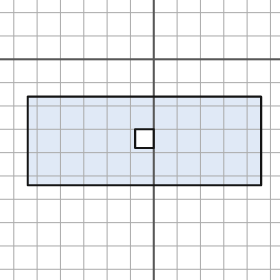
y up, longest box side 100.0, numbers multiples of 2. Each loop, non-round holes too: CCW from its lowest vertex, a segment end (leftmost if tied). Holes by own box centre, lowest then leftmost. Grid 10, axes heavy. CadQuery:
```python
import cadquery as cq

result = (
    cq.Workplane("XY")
    .moveTo(-54.0, -54.0)
    .lineTo(46.0, -54.0)
    .lineTo(46.0, -16.0)
    .lineTo(-54.0, -16.0)
    .close()
    .moveTo(-8.0, -38.0)
    .lineTo(0.0, -38.0)
    .lineTo(0.0, -30.0)
    .lineTo(-8.0, -30.0)
    .close()
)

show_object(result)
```